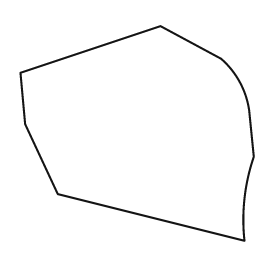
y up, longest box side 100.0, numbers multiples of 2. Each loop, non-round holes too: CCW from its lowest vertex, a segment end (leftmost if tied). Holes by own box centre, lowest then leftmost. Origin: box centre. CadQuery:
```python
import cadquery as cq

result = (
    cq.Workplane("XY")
    .moveTo(46.0, -46.0)
    .threePointArc((46.0, -28.0), (50.0, -10.0))
    .lineTo(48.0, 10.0)
    .threePointArc((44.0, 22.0), (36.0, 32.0))
    .lineTo(10.0, 46.0)
    .lineTo(-50.0, 26.0)
    .lineTo(-48.0, 4.0)
    .lineTo(-34.0, -26.0)
    .close()
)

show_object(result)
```